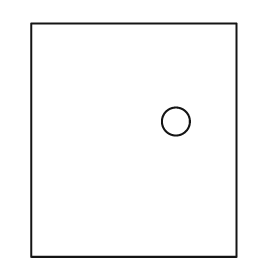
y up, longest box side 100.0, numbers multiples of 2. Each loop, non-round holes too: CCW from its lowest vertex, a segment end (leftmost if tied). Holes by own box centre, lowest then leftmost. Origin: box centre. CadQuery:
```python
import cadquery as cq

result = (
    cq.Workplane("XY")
    .moveTo(-44.0, -50.0)
    .lineTo(44.0, -50.0)
    .lineTo(44.0, 50.0)
    .lineTo(-44.0, 50.0)
    .close()
    .moveTo(18.0, 8.0)
    .circle(6.0)
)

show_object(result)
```